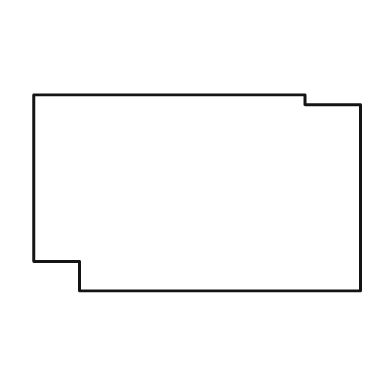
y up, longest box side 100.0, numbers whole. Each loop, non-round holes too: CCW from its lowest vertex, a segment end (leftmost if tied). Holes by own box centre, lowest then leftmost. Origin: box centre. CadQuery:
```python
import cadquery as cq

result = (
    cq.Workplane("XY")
    .moveTo(-36.0, -30.0)
    .lineTo(50.0, -30.0)
    .lineTo(50.0, 27.0)
    .lineTo(33.0, 27.0)
    .lineTo(33.0, 30.0)
    .lineTo(-50.0, 30.0)
    .lineTo(-50.0, -21.0)
    .lineTo(-36.0, -21.0)
    .close()
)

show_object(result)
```